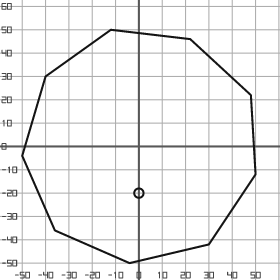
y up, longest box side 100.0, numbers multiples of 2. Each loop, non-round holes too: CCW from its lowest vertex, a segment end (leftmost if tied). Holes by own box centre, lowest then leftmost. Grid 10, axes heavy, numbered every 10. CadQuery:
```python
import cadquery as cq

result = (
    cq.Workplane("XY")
    .moveTo(-4.0, -50.0)
    .lineTo(30.0, -42.0)
    .lineTo(50.0, -12.0)
    .lineTo(48.0, 22.0)
    .lineTo(22.0, 46.0)
    .lineTo(-12.0, 50.0)
    .lineTo(-40.0, 30.0)
    .lineTo(-50.0, -4.0)
    .lineTo(-36.0, -36.0)
    .close()
    .moveTo(0.0, -20.0)
    .circle(2.0)
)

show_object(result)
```